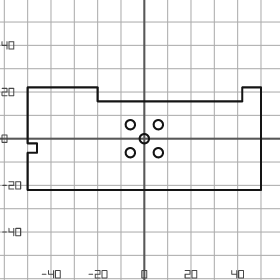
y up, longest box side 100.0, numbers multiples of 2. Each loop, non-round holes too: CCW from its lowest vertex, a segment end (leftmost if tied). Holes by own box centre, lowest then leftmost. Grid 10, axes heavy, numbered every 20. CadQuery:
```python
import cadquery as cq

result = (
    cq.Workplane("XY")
    .moveTo(-50.0, -22.0)
    .lineTo(50.0, -22.0)
    .lineTo(50.0, 22.0)
    .lineTo(42.0, 22.0)
    .lineTo(42.0, 16.0)
    .lineTo(-20.0, 16.0)
    .lineTo(-20.0, 22.0)
    .lineTo(-50.0, 22.0)
    .lineTo(-50.0, -2.0)
    .lineTo(-46.0, -2.0)
    .lineTo(-46.0, -6.0)
    .lineTo(-50.0, -6.0)
    .close()
    .moveTo(-6.0, -6.0)
    .circle(2.0)
    .moveTo(6.0, -6.0)
    .circle(2.0)
    .moveTo(0.0, 0.0)
    .circle(2.0)
    .moveTo(-6.0, 6.0)
    .circle(2.0)
    .moveTo(6.0, 6.0)
    .circle(2.0)
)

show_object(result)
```